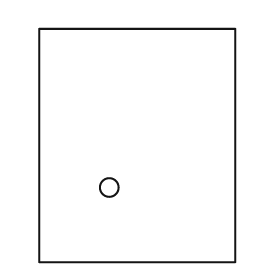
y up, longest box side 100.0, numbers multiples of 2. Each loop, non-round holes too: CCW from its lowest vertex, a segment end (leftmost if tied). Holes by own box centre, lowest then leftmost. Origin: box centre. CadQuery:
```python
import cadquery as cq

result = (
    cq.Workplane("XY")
    .moveTo(-42.0, -50.0)
    .lineTo(42.0, -50.0)
    .lineTo(42.0, 50.0)
    .lineTo(-42.0, 50.0)
    .close()
    .moveTo(-12.0, -18.0)
    .circle(4.0)
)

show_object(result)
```